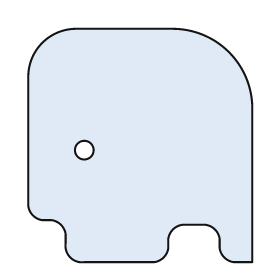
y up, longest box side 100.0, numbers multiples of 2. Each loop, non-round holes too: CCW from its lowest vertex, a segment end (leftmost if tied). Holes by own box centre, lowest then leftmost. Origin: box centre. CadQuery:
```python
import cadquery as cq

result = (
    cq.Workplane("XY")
    .moveTo(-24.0, -50.0)
    .lineTo(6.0, -50.0)
    .threePointArc((10.0, -48.0), (12.0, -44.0))
    .lineTo(12.0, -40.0)
    .threePointArc((14.0, -36.0), (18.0, -34.0))
    .lineTo(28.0, -34.0)
    .threePointArc((32.0, -36.0), (34.0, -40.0))
    .lineTo(34.0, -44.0)
    .threePointArc((36.0, -48.0), (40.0, -50.0))
    .lineTo(48.0, -50.0)
    .lineTo(48.0, 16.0)
    .threePointArc((38.0, 40.0), (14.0, 50.0))
    .lineTo(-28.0, 50.0)
    .threePointArc((-42.0, 44.0), (-48.0, 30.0))
    .lineTo(-48.0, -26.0)
    .threePointArc((-46.0, -30.0), (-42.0, -32.0))
    .lineTo(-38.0, -32.0)
    .threePointArc((-34.0, -34.0), (-32.0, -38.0))
    .lineTo(-32.0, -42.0)
    .threePointArc((-30.0, -48.0), (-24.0, -50.0))
    .close()
    .moveTo(-24.0, -2.0)
    .circle(4.0)
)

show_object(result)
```